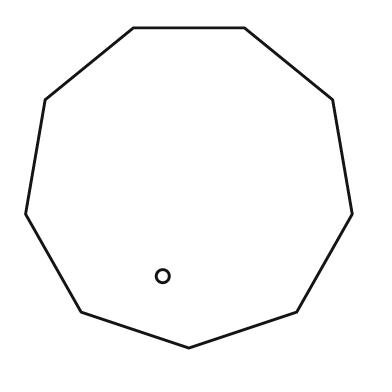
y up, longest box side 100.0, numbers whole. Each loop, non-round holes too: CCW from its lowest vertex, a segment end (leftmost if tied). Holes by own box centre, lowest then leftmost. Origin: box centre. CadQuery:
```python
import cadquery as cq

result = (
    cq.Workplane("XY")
    .moveTo(0.0, -49.0)
    .lineTo(33.0, -38.0)
    .lineTo(50.0, -8.0)
    .lineTo(44.0, 27.0)
    .lineTo(17.0, 49.0)
    .lineTo(-17.0, 49.0)
    .lineTo(-44.0, 27.0)
    .lineTo(-50.0, -8.0)
    .lineTo(-33.0, -38.0)
    .close()
    .moveTo(-8.0, -27.0)
    .circle(2.0)
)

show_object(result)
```